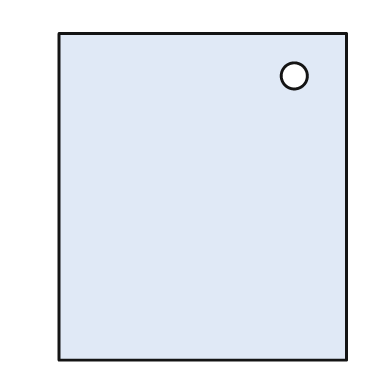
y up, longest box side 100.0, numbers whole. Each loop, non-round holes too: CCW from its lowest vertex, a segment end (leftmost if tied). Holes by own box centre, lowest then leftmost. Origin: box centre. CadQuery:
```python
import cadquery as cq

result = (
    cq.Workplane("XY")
    .moveTo(-44.0, -50.0)
    .lineTo(44.0, -50.0)
    .lineTo(44.0, 50.0)
    .lineTo(-44.0, 50.0)
    .close()
    .moveTo(28.0, 37.0)
    .circle(4.0)
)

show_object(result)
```